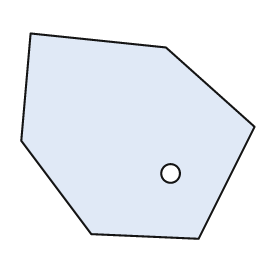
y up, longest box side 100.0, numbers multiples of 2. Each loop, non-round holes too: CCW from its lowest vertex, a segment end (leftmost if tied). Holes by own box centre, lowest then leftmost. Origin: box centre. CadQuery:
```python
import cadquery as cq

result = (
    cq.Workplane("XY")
    .moveTo(26.0, -44.0)
    .lineTo(50.0, 4.0)
    .lineTo(12.0, 38.0)
    .lineTo(-46.0, 44.0)
    .lineTo(-50.0, -2.0)
    .lineTo(-20.0, -42.0)
    .close()
    .moveTo(14.0, -16.0)
    .circle(4.0)
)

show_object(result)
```